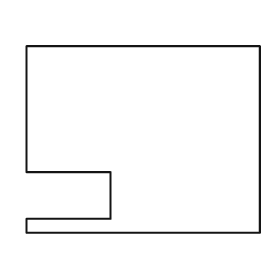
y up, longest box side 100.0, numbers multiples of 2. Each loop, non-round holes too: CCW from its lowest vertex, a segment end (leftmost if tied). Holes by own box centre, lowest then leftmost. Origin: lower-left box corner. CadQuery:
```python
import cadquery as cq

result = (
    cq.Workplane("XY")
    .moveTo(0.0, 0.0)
    .lineTo(100.0, 0.0)
    .lineTo(100.0, 80.0)
    .lineTo(0.0, 80.0)
    .lineTo(0.0, 26.0)
    .lineTo(36.0, 26.0)
    .lineTo(36.0, 6.0)
    .lineTo(0.0, 6.0)
    .close()
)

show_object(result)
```